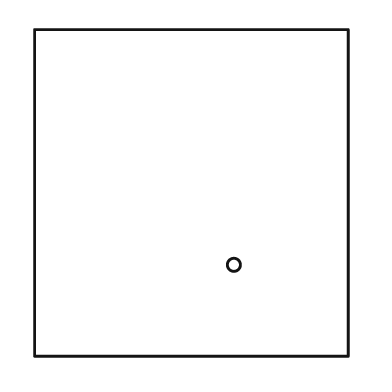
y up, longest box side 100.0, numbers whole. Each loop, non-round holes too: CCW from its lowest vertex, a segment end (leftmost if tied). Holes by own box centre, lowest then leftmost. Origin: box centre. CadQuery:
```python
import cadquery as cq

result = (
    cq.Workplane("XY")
    .moveTo(-48.0, -50.0)
    .lineTo(48.0, -50.0)
    .lineTo(48.0, 50.0)
    .lineTo(-48.0, 50.0)
    .close()
    .moveTo(13.0, -22.0)
    .circle(2.0)
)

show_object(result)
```